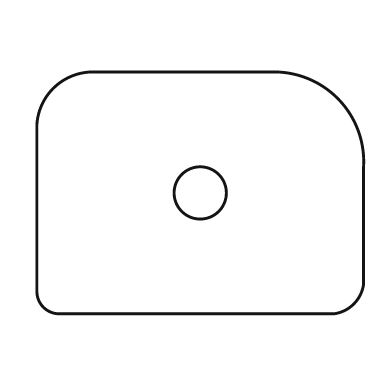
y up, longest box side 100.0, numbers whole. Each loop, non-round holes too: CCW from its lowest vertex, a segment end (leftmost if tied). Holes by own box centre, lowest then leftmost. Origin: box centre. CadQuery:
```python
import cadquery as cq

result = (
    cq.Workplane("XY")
    .moveTo(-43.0, -37.0)
    .lineTo(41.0, -37.0)
    .threePointArc((47.0, -34.0), (50.0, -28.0))
    .lineTo(50.0, 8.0)
    .threePointArc((42.0, 29.0), (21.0, 37.0))
    .lineTo(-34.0, 37.0)
    .threePointArc((-45.0, 32.0), (-50.0, 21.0))
    .lineTo(-50.0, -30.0)
    .threePointArc((-48.0, -35.0), (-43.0, -37.0))
    .close()
    .moveTo(0.0, 0.0)
    .circle(8.0)
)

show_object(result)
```